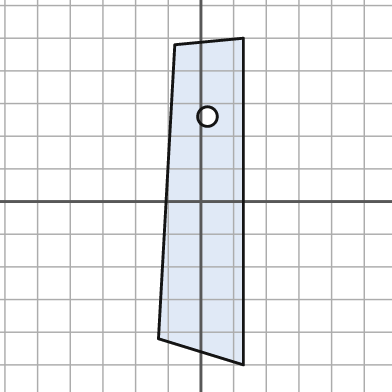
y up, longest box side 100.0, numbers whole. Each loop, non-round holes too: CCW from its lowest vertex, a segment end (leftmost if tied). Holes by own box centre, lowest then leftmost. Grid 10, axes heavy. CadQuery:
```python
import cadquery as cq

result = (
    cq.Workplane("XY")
    .moveTo(13.0, -50.0)
    .lineTo(13.0, 50.0)
    .lineTo(-8.0, 48.0)
    .lineTo(-13.0, -42.0)
    .close()
    .moveTo(2.0, 26.0)
    .circle(3.0)
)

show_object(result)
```